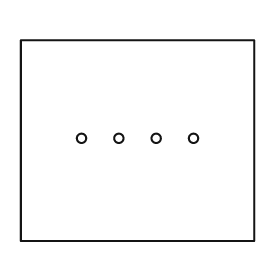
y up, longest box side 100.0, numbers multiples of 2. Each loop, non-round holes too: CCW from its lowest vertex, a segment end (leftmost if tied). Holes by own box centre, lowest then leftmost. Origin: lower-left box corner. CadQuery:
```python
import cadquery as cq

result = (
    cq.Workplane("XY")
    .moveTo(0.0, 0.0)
    .lineTo(100.0, 0.0)
    .lineTo(100.0, 86.0)
    .lineTo(0.0, 86.0)
    .close()
    .moveTo(26.0, 44.0)
    .circle(2.0)
    .moveTo(42.0, 44.0)
    .circle(2.0)
    .moveTo(58.0, 44.0)
    .circle(2.0)
    .moveTo(74.0, 44.0)
    .circle(2.0)
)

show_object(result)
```